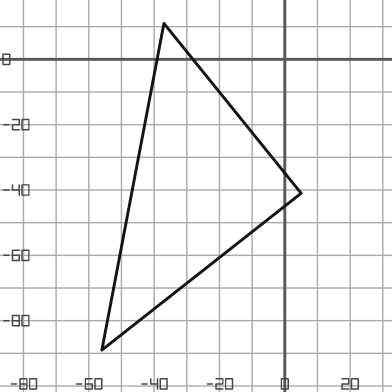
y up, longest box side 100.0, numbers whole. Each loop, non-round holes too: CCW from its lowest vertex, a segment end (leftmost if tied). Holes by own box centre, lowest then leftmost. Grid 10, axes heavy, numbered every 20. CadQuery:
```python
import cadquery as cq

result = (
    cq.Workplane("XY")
    .moveTo(-56.0, -89.0)
    .lineTo(5.0, -41.0)
    .lineTo(-37.0, 11.0)
    .close()
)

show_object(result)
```